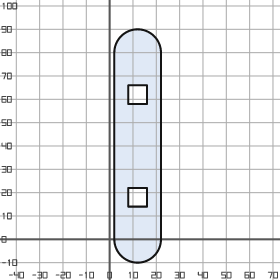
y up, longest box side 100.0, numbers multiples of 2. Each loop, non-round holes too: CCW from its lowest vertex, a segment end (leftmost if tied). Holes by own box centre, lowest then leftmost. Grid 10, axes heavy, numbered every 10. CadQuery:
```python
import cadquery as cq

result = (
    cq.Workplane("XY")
    .moveTo(2.0, 0.0)
    .threePointArc((12.0, -10.0), (22.0, 0.0))
    .lineTo(22.0, 80.0)
    .threePointArc((12.0, 90.0), (2.0, 80.0))
    .close()
    .moveTo(8.0, 14.0)
    .lineTo(16.0, 14.0)
    .lineTo(16.0, 22.0)
    .lineTo(8.0, 22.0)
    .close()
    .moveTo(8.0, 58.0)
    .lineTo(16.0, 58.0)
    .lineTo(16.0, 66.0)
    .lineTo(8.0, 66.0)
    .close()
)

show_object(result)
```